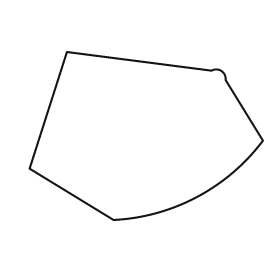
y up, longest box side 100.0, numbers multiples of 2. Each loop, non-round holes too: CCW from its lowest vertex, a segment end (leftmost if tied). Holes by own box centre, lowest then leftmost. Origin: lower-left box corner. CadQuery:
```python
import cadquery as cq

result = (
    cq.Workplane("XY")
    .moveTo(36.0, 0.0)
    .threePointArc((72.0, 10.0), (100.0, 34.0))
    .lineTo(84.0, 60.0)
    .threePointArc((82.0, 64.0), (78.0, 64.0))
    .lineTo(16.0, 72.0)
    .lineTo(0.0, 22.0)
    .close()
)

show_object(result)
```